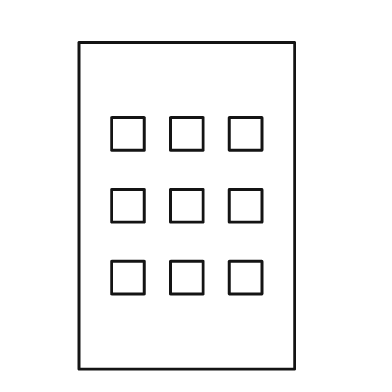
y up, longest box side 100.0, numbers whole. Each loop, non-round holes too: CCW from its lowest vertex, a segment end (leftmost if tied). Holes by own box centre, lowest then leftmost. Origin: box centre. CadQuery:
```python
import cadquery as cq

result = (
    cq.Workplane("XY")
    .moveTo(-33.0, -50.0)
    .lineTo(33.0, -50.0)
    .lineTo(33.0, 50.0)
    .lineTo(-33.0, 50.0)
    .close()
    .moveTo(-23.0, -27.0)
    .lineTo(-13.0, -27.0)
    .lineTo(-13.0, -17.0)
    .lineTo(-23.0, -17.0)
    .close()
    .moveTo(-5.0, -27.0)
    .lineTo(5.0, -27.0)
    .lineTo(5.0, -17.0)
    .lineTo(-5.0, -17.0)
    .close()
    .moveTo(13.0, -27.0)
    .lineTo(23.0, -27.0)
    .lineTo(23.0, -17.0)
    .lineTo(13.0, -17.0)
    .close()
    .moveTo(-23.0, -5.0)
    .lineTo(-13.0, -5.0)
    .lineTo(-13.0, 5.0)
    .lineTo(-23.0, 5.0)
    .close()
    .moveTo(-5.0, -5.0)
    .lineTo(5.0, -5.0)
    .lineTo(5.0, 5.0)
    .lineTo(-5.0, 5.0)
    .close()
    .moveTo(13.0, -5.0)
    .lineTo(23.0, -5.0)
    .lineTo(23.0, 5.0)
    .lineTo(13.0, 5.0)
    .close()
    .moveTo(-23.0, 17.0)
    .lineTo(-13.0, 17.0)
    .lineTo(-13.0, 27.0)
    .lineTo(-23.0, 27.0)
    .close()
    .moveTo(-5.0, 17.0)
    .lineTo(5.0, 17.0)
    .lineTo(5.0, 27.0)
    .lineTo(-5.0, 27.0)
    .close()
    .moveTo(13.0, 17.0)
    .lineTo(23.0, 17.0)
    .lineTo(23.0, 27.0)
    .lineTo(13.0, 27.0)
    .close()
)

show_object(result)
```